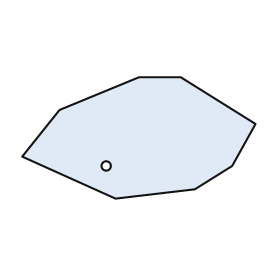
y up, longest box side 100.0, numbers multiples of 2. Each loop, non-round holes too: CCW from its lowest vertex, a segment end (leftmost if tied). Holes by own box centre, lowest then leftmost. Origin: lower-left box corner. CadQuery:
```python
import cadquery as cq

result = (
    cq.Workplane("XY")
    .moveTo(40.0, 0.0)
    .lineTo(74.0, 4.0)
    .lineTo(90.0, 14.0)
    .lineTo(100.0, 32.0)
    .lineTo(68.0, 52.0)
    .lineTo(50.0, 52.0)
    .lineTo(16.0, 38.0)
    .lineTo(0.0, 18.0)
    .close()
    .moveTo(36.0, 14.0)
    .circle(2.0)
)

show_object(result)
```